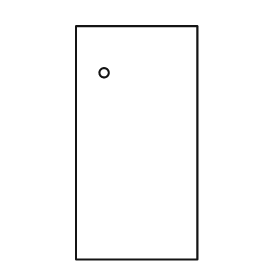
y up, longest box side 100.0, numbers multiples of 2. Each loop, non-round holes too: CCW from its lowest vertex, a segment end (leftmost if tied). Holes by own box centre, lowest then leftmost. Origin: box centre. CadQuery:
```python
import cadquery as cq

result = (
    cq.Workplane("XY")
    .moveTo(-26.0, -50.0)
    .lineTo(26.0, -50.0)
    .lineTo(26.0, 50.0)
    .lineTo(-26.0, 50.0)
    .close()
    .moveTo(-14.0, 30.0)
    .circle(2.0)
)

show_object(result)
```